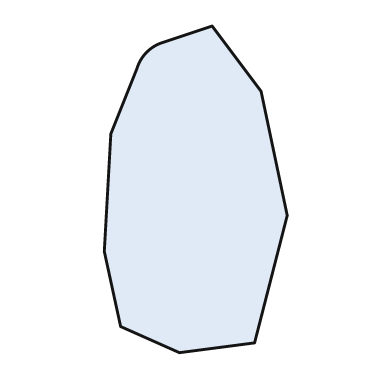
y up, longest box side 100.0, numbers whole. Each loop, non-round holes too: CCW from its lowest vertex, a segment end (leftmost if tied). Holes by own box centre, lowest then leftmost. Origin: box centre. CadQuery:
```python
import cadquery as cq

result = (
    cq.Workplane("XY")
    .moveTo(-5.0, -50.0)
    .lineTo(18.0, -47.0)
    .lineTo(28.0, -8.0)
    .lineTo(20.0, 30.0)
    .lineTo(5.0, 50.0)
    .lineTo(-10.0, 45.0)
    .threePointArc((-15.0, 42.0), (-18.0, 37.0))
    .lineTo(-26.0, 17.0)
    .lineTo(-28.0, -19.0)
    .lineTo(-23.0, -42.0)
    .close()
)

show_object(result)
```